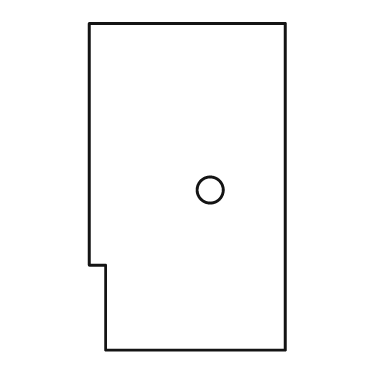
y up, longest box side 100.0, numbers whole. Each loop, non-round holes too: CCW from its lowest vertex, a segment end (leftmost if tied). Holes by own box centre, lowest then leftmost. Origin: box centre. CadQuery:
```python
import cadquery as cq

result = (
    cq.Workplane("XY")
    .moveTo(-25.0, -50.0)
    .lineTo(30.0, -50.0)
    .lineTo(30.0, 50.0)
    .lineTo(-30.0, 50.0)
    .lineTo(-30.0, -24.0)
    .lineTo(-25.0, -24.0)
    .close()
    .moveTo(7.0, -1.0)
    .circle(4.0)
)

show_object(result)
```